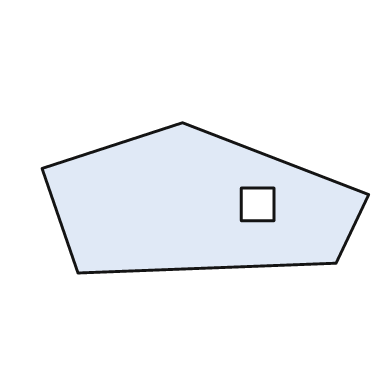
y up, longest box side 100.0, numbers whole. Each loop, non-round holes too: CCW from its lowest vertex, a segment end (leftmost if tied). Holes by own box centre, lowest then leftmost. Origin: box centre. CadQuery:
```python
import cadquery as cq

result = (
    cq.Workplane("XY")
    .moveTo(-39.0, -23.0)
    .lineTo(40.0, -20.0)
    .lineTo(50.0, 1.0)
    .lineTo(-7.0, 23.0)
    .lineTo(-50.0, 9.0)
    .close()
    .moveTo(11.0, -7.0)
    .lineTo(21.0, -7.0)
    .lineTo(21.0, 3.0)
    .lineTo(11.0, 3.0)
    .close()
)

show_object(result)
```